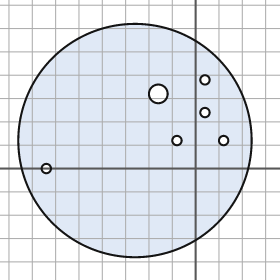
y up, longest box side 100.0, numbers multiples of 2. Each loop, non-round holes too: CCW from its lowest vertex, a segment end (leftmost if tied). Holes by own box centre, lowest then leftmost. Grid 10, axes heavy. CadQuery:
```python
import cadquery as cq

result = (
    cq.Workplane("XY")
    .moveTo(-26.0, 12.0)
    .circle(50.0)
    .moveTo(-64.0, 0.0)
    .circle(2.0)
    .moveTo(-8.0, 12.0)
    .circle(2.0)
    .moveTo(12.0, 12.0)
    .circle(2.0)
    .moveTo(4.0, 24.0)
    .circle(2.0)
    .moveTo(-16.0, 32.0)
    .circle(4.0)
    .moveTo(4.0, 38.0)
    .circle(2.0)
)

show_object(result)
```